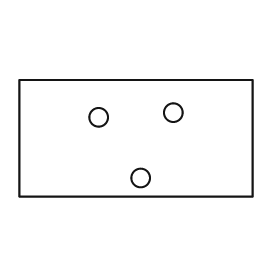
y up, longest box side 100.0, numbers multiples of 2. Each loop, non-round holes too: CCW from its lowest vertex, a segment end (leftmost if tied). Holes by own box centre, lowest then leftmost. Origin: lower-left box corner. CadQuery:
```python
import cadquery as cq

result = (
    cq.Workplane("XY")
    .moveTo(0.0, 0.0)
    .lineTo(100.0, 0.0)
    .lineTo(100.0, 50.0)
    .lineTo(0.0, 50.0)
    .close()
    .moveTo(52.0, 8.0)
    .circle(4.0)
    .moveTo(34.0, 34.0)
    .circle(4.0)
    .moveTo(66.0, 36.0)
    .circle(4.0)
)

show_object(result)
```